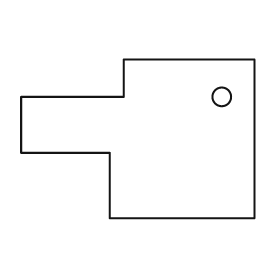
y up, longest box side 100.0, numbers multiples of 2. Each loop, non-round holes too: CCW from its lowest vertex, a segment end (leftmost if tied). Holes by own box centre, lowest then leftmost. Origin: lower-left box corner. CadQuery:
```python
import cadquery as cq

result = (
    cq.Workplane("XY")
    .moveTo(38.0, 0.0)
    .lineTo(100.0, 0.0)
    .lineTo(100.0, 68.0)
    .lineTo(44.0, 68.0)
    .lineTo(44.0, 52.0)
    .lineTo(0.0, 52.0)
    .lineTo(0.0, 28.0)
    .lineTo(38.0, 28.0)
    .close()
    .moveTo(86.0, 52.0)
    .circle(4.0)
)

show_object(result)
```